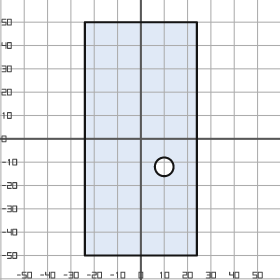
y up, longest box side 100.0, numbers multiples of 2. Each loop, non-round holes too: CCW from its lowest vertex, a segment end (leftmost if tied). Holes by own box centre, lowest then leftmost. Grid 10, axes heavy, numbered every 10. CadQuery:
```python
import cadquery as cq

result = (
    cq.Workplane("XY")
    .moveTo(-24.0, -50.0)
    .lineTo(24.0, -50.0)
    .lineTo(24.0, 50.0)
    .lineTo(-24.0, 50.0)
    .close()
    .moveTo(10.0, -12.0)
    .circle(4.0)
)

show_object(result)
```